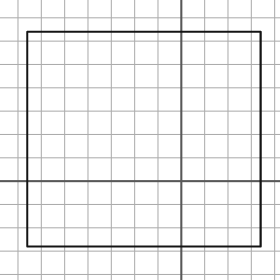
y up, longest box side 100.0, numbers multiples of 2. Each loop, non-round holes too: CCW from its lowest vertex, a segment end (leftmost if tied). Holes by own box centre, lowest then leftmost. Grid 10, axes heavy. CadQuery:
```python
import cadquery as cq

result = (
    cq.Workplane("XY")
    .moveTo(-66.0, -28.0)
    .lineTo(34.0, -28.0)
    .lineTo(34.0, 64.0)
    .lineTo(-66.0, 64.0)
    .close()
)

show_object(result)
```